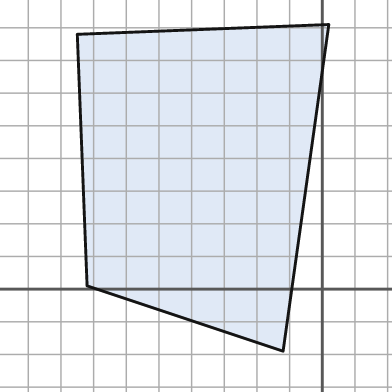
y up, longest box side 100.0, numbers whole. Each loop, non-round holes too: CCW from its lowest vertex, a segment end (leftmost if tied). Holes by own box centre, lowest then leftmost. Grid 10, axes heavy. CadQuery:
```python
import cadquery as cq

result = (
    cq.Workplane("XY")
    .moveTo(-12.0, -19.0)
    .lineTo(2.0, 81.0)
    .lineTo(-75.0, 78.0)
    .lineTo(-72.0, 1.0)
    .close()
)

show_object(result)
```